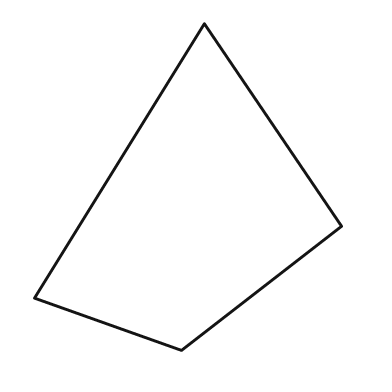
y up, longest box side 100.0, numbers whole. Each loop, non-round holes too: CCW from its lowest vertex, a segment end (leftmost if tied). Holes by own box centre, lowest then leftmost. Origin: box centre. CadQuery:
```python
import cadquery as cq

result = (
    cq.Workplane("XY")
    .moveTo(-2.0, -50.0)
    .lineTo(47.0, -12.0)
    .lineTo(5.0, 50.0)
    .lineTo(-47.0, -34.0)
    .close()
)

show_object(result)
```